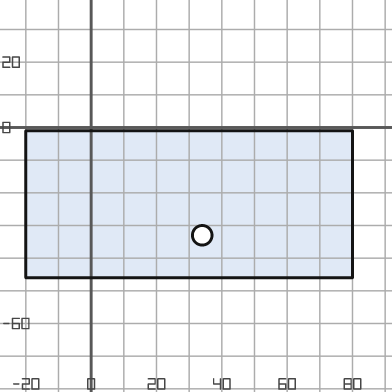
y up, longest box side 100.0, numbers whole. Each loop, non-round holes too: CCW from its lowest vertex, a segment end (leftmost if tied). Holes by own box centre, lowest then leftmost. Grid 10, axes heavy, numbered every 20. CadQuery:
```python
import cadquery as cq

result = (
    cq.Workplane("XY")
    .moveTo(-20.0, -46.0)
    .lineTo(80.0, -46.0)
    .lineTo(80.0, -1.0)
    .lineTo(-20.0, -1.0)
    .close()
    .moveTo(34.0, -33.0)
    .circle(3.0)
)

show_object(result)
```